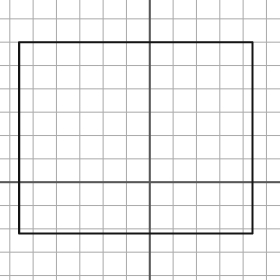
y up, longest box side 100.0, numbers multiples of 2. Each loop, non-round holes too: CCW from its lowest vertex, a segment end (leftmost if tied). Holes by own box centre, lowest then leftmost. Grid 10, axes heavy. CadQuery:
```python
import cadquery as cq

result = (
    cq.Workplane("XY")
    .moveTo(-56.0, -22.0)
    .lineTo(44.0, -22.0)
    .lineTo(44.0, 60.0)
    .lineTo(-56.0, 60.0)
    .close()
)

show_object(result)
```